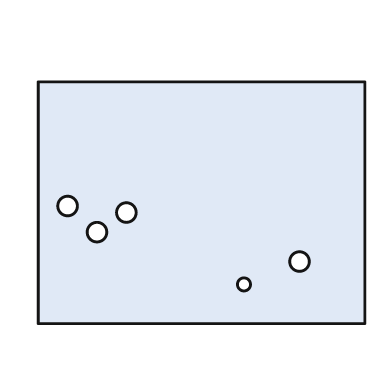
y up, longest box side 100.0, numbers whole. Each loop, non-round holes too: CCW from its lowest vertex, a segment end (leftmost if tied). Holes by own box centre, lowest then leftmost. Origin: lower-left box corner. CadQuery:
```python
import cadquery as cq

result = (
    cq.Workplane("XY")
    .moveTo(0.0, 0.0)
    .lineTo(100.0, 0.0)
    .lineTo(100.0, 74.0)
    .lineTo(0.0, 74.0)
    .close()
    .moveTo(63.0, 12.0)
    .circle(2.0)
    .moveTo(80.0, 19.0)
    .circle(3.0)
    .moveTo(18.0, 28.0)
    .circle(3.0)
    .moveTo(27.0, 34.0)
    .circle(3.0)
    .moveTo(9.0, 36.0)
    .circle(3.0)
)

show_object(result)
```